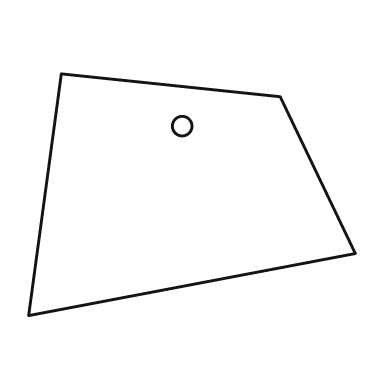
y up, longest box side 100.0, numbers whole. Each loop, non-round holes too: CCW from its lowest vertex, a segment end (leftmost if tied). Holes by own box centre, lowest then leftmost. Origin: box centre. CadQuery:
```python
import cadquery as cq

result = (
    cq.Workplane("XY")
    .moveTo(-50.0, -37.0)
    .lineTo(50.0, -18.0)
    .lineTo(27.0, 30.0)
    .lineTo(-40.0, 37.0)
    .close()
    .moveTo(-3.0, 21.0)
    .circle(3.0)
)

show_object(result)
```